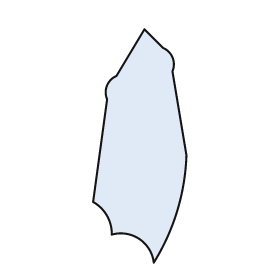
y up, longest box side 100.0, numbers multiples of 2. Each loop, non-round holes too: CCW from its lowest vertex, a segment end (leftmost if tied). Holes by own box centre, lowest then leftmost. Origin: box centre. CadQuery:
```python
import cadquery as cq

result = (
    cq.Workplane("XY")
    .moveTo(6.0, -50.0)
    .threePointArc((16.0, -28.0), (20.0, -4.0))
    .lineTo(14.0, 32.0)
    .threePointArc((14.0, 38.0), (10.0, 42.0))
    .lineTo(2.0, 50.0)
    .lineTo(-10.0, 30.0)
    .threePointArc((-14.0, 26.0), (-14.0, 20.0))
    .lineTo(-20.0, -24.0)
    .threePointArc((-14.0, -30.0), (-12.0, -38.0))
    .threePointArc((0.0, -40.0), (6.0, -50.0))
    .close()
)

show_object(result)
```